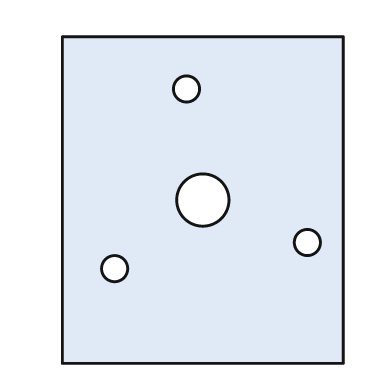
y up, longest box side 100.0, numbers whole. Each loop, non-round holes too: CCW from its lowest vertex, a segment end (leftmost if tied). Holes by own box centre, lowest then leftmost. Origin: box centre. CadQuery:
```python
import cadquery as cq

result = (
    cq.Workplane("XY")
    .moveTo(-43.0, -50.0)
    .lineTo(43.0, -50.0)
    .lineTo(43.0, 50.0)
    .lineTo(-43.0, 50.0)
    .close()
    .moveTo(-27.0, -21.0)
    .circle(4.0)
    .moveTo(32.0, -13.0)
    .circle(4.0)
    .moveTo(0.0, 0.0)
    .circle(8.0)
    .moveTo(-5.0, 34.0)
    .circle(4.0)
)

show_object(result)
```